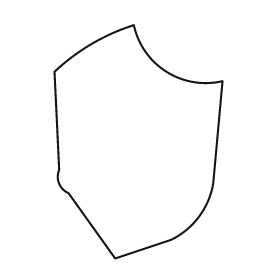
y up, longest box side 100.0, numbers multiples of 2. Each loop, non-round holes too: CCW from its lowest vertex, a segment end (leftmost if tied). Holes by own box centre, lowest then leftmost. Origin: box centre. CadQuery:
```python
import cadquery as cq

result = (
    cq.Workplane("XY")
    .moveTo(-10.0, -50.0)
    .lineTo(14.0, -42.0)
    .threePointArc((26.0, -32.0), (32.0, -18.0))
    .lineTo(36.0, 26.0)
    .threePointArc((12.0, 30.0), (-2.0, 50.0))
    .threePointArc((-20.0, 42.0), (-36.0, 30.0))
    .lineTo(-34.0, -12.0)
    .threePointArc((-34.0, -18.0), (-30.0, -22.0))
    .close()
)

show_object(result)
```